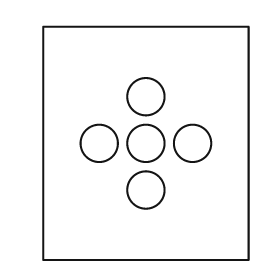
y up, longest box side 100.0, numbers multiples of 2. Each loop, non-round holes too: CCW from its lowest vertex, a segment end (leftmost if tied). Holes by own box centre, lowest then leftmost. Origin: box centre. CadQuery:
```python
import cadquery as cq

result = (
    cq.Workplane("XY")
    .moveTo(-44.0, -50.0)
    .lineTo(44.0, -50.0)
    .lineTo(44.0, 50.0)
    .lineTo(-44.0, 50.0)
    .close()
    .moveTo(0.0, -20.0)
    .circle(8.0)
    .moveTo(-20.0, 0.0)
    .circle(8.0)
    .moveTo(0.0, 0.0)
    .circle(8.0)
    .moveTo(20.0, 0.0)
    .circle(8.0)
    .moveTo(0.0, 20.0)
    .circle(8.0)
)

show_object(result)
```